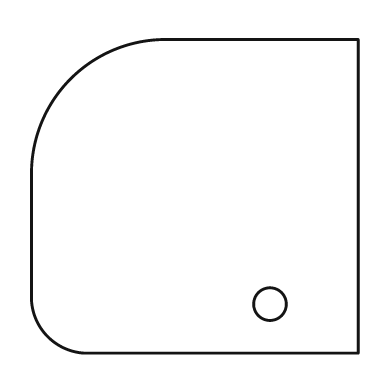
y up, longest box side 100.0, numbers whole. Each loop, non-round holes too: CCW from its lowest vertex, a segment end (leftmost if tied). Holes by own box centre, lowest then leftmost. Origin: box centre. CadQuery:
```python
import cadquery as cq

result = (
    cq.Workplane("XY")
    .moveTo(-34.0, -48.0)
    .lineTo(50.0, -48.0)
    .lineTo(50.0, 48.0)
    .lineTo(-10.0, 48.0)
    .threePointArc((-38.0, 36.0), (-50.0, 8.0))
    .lineTo(-50.0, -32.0)
    .threePointArc((-45.0, -43.0), (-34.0, -48.0))
    .close()
    .moveTo(23.0, -33.0)
    .circle(5.0)
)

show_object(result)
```